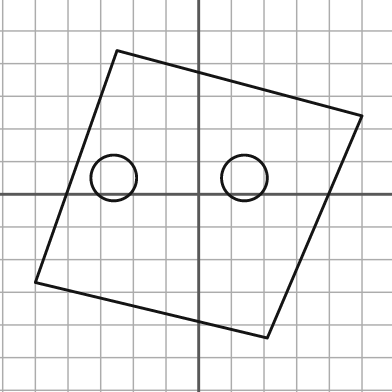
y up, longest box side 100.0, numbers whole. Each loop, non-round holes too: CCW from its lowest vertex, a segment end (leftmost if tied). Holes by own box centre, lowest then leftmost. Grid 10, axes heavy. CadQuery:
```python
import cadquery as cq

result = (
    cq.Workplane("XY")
    .moveTo(21.0, -44.0)
    .lineTo(50.0, 24.0)
    .lineTo(-25.0, 44.0)
    .lineTo(-50.0, -27.0)
    .close()
    .moveTo(-26.0, 5.0)
    .circle(7.0)
    .moveTo(14.0, 5.0)
    .circle(7.0)
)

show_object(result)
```